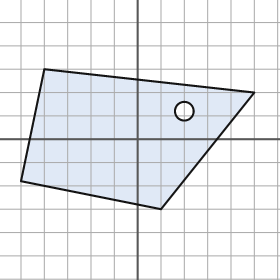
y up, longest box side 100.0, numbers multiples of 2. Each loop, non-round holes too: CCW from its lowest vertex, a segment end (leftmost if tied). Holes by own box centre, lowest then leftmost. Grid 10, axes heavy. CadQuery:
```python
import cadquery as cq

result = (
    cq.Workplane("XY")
    .moveTo(10.0, -30.0)
    .lineTo(50.0, 20.0)
    .lineTo(-40.0, 30.0)
    .lineTo(-50.0, -18.0)
    .close()
    .moveTo(20.0, 12.0)
    .circle(4.0)
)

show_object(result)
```